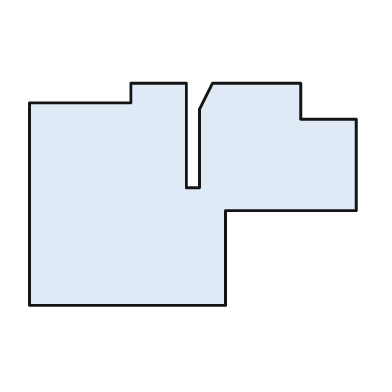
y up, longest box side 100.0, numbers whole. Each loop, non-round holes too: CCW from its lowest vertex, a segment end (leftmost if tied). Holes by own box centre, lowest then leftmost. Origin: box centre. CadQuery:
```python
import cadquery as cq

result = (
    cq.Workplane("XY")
    .moveTo(-50.0, -34.0)
    .lineTo(10.0, -34.0)
    .lineTo(10.0, -5.0)
    .lineTo(50.0, -5.0)
    .lineTo(50.0, 23.0)
    .lineTo(33.0, 23.0)
    .lineTo(33.0, 34.0)
    .lineTo(6.0, 34.0)
    .lineTo(2.0, 26.0)
    .lineTo(2.0, 2.0)
    .lineTo(-2.0, 2.0)
    .lineTo(-2.0, 34.0)
    .lineTo(-19.0, 34.0)
    .lineTo(-19.0, 28.0)
    .lineTo(-50.0, 28.0)
    .close()
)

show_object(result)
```